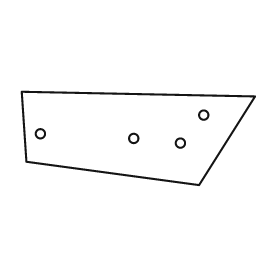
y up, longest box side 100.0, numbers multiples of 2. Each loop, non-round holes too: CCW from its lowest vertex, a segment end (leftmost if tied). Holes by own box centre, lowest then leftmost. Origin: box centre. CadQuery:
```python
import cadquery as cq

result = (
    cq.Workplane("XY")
    .moveTo(26.0, -20.0)
    .lineTo(50.0, 18.0)
    .lineTo(-50.0, 20.0)
    .lineTo(-48.0, -10.0)
    .close()
    .moveTo(18.0, -2.0)
    .circle(2.0)
    .moveTo(-2.0, 0.0)
    .circle(2.0)
    .moveTo(-42.0, 2.0)
    .circle(2.0)
    .moveTo(28.0, 10.0)
    .circle(2.0)
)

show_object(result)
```